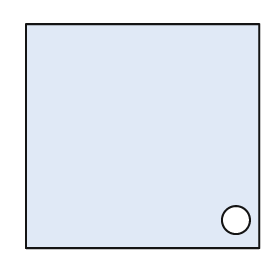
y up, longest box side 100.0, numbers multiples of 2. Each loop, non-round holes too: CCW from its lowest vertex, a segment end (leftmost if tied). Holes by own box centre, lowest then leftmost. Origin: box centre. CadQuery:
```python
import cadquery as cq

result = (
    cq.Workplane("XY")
    .moveTo(-50.0, -48.0)
    .lineTo(50.0, -48.0)
    .lineTo(50.0, 48.0)
    .lineTo(-50.0, 48.0)
    .close()
    .moveTo(40.0, -36.0)
    .circle(6.0)
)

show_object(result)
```